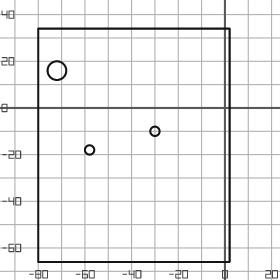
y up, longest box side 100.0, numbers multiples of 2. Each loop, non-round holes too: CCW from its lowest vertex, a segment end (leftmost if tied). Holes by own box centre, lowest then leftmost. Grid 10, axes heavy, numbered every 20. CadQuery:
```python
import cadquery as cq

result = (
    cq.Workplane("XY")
    .moveTo(-80.0, -66.0)
    .lineTo(2.0, -66.0)
    .lineTo(2.0, 34.0)
    .lineTo(-80.0, 34.0)
    .close()
    .moveTo(-58.0, -18.0)
    .circle(2.0)
    .moveTo(-30.0, -10.0)
    .circle(2.0)
    .moveTo(-72.0, 16.0)
    .circle(4.0)
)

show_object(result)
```